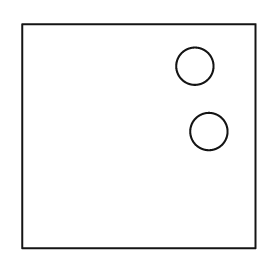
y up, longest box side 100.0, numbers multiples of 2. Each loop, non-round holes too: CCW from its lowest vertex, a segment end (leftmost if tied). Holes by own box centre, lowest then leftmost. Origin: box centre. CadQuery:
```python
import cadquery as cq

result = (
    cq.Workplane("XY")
    .moveTo(-50.0, -48.0)
    .lineTo(50.0, -48.0)
    .lineTo(50.0, 48.0)
    .lineTo(-50.0, 48.0)
    .close()
    .moveTo(30.0, 2.0)
    .circle(8.0)
    .moveTo(24.0, 30.0)
    .circle(8.0)
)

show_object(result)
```